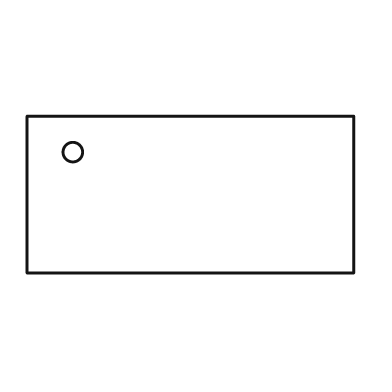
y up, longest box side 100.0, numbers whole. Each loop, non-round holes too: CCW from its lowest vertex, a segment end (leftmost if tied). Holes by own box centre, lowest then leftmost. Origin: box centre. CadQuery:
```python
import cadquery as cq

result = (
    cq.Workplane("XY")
    .moveTo(-50.0, -24.0)
    .lineTo(50.0, -24.0)
    .lineTo(50.0, 24.0)
    .lineTo(-50.0, 24.0)
    .close()
    .moveTo(-36.0, 13.0)
    .circle(3.0)
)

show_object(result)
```